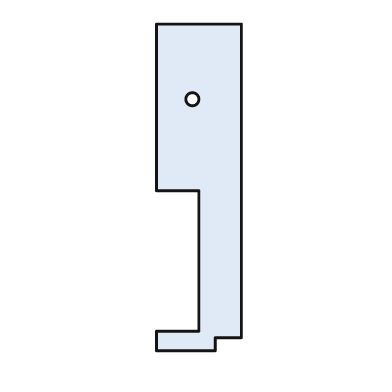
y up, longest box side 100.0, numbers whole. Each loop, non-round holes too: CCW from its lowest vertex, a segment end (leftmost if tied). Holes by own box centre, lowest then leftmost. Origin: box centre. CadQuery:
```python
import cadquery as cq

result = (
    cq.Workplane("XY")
    .moveTo(-13.0, -50.0)
    .lineTo(5.0, -50.0)
    .lineTo(5.0, -46.0)
    .lineTo(13.0, -46.0)
    .lineTo(13.0, 50.0)
    .lineTo(-13.0, 50.0)
    .lineTo(-13.0, -1.0)
    .lineTo(0.0, -1.0)
    .lineTo(0.0, -44.0)
    .lineTo(-13.0, -44.0)
    .close()
    .moveTo(-2.0, 27.0)
    .circle(2.0)
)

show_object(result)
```